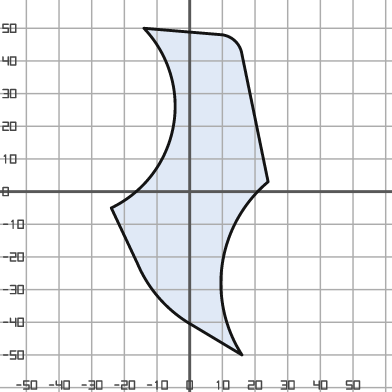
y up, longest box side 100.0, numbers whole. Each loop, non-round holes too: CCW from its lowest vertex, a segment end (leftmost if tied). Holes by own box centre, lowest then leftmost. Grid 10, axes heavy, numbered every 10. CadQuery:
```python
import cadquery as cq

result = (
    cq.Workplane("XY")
    .moveTo(16.0, -50.0)
    .threePointArc((10.0, -22.0), (24.0, 3.0))
    .lineTo(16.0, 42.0)
    .threePointArc((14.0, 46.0), (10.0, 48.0))
    .lineTo(-14.0, 50.0)
    .threePointArc((-5.0, 20.0), (-24.0, -5.0))
    .lineTo(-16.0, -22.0)
    .threePointArc((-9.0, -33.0), (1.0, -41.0))
    .close()
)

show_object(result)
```